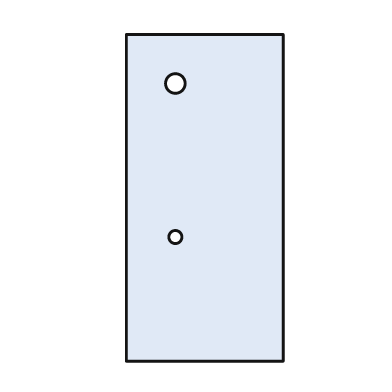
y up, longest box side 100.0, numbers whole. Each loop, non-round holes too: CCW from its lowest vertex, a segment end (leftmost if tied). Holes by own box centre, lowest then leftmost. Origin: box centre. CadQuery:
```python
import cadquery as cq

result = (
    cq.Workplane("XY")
    .moveTo(-24.0, -50.0)
    .lineTo(24.0, -50.0)
    .lineTo(24.0, 50.0)
    .lineTo(-24.0, 50.0)
    .close()
    .moveTo(-9.0, -12.0)
    .circle(2.0)
    .moveTo(-9.0, 35.0)
    .circle(3.0)
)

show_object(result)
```